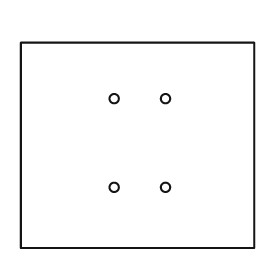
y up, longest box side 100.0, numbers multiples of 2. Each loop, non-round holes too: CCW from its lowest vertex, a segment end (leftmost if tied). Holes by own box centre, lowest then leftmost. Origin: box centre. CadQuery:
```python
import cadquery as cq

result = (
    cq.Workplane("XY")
    .moveTo(-50.0, -44.0)
    .lineTo(50.0, -44.0)
    .lineTo(50.0, 44.0)
    .lineTo(-50.0, 44.0)
    .close()
    .moveTo(-10.0, -18.0)
    .circle(2.0)
    .moveTo(12.0, -18.0)
    .circle(2.0)
    .moveTo(-10.0, 20.0)
    .circle(2.0)
    .moveTo(12.0, 20.0)
    .circle(2.0)
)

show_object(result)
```